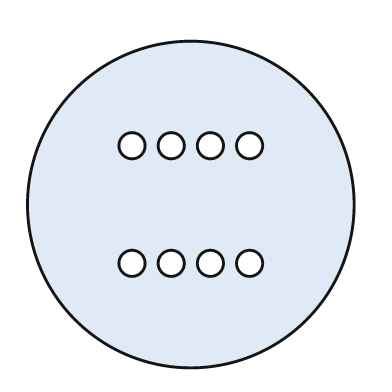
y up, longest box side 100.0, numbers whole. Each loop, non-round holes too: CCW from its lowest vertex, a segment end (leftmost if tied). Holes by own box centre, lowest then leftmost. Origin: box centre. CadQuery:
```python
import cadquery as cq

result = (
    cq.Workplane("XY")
    .moveTo(0.0, 0.0)
    .circle(50.0)
    .moveTo(-18.0, -18.0)
    .circle(4.0)
    .moveTo(-6.0, -18.0)
    .circle(4.0)
    .moveTo(6.0, -18.0)
    .circle(4.0)
    .moveTo(18.0, -18.0)
    .circle(4.0)
    .moveTo(-18.0, 18.0)
    .circle(4.0)
    .moveTo(-6.0, 18.0)
    .circle(4.0)
    .moveTo(6.0, 18.0)
    .circle(4.0)
    .moveTo(18.0, 18.0)
    .circle(4.0)
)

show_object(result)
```